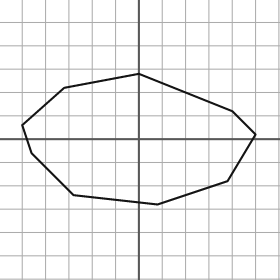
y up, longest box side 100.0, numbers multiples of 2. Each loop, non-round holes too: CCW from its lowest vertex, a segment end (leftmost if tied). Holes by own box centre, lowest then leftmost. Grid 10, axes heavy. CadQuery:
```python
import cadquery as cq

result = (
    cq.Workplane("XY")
    .moveTo(8.0, -28.0)
    .lineTo(38.0, -18.0)
    .lineTo(50.0, 2.0)
    .lineTo(40.0, 12.0)
    .lineTo(0.0, 28.0)
    .lineTo(-32.0, 22.0)
    .lineTo(-50.0, 6.0)
    .lineTo(-46.0, -6.0)
    .lineTo(-28.0, -24.0)
    .close()
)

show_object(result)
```